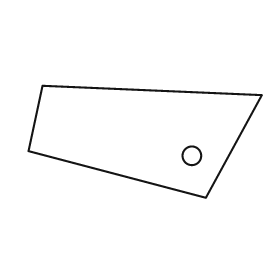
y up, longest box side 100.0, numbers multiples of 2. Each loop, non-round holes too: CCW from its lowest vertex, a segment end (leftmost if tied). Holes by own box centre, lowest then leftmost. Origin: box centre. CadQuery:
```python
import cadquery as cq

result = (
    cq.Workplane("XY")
    .moveTo(26.0, -24.0)
    .lineTo(50.0, 20.0)
    .lineTo(-44.0, 24.0)
    .lineTo(-50.0, -4.0)
    .close()
    .moveTo(20.0, -6.0)
    .circle(4.0)
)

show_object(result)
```